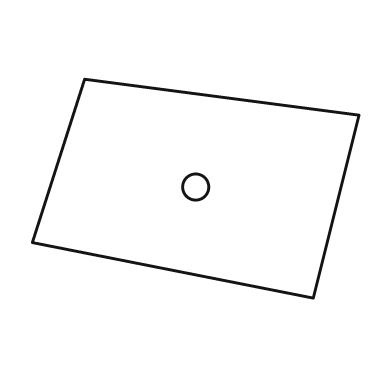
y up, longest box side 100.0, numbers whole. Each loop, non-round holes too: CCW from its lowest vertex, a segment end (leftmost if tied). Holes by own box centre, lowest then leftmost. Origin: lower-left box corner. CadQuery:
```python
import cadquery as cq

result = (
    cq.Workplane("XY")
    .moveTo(86.0, 0.0)
    .lineTo(100.0, 56.0)
    .lineTo(16.0, 67.0)
    .lineTo(0.0, 17.0)
    .close()
    .moveTo(50.0, 34.0)
    .circle(4.0)
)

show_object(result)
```